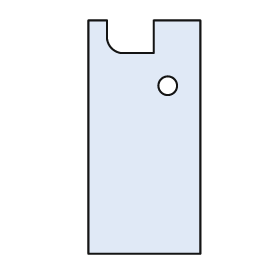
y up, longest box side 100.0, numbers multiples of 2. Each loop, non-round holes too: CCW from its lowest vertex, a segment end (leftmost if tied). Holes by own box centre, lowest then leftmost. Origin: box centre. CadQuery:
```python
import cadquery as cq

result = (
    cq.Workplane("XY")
    .moveTo(-24.0, -50.0)
    .lineTo(24.0, -50.0)
    .lineTo(24.0, 50.0)
    .lineTo(4.0, 50.0)
    .lineTo(4.0, 36.0)
    .lineTo(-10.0, 36.0)
    .threePointArc((-14.0, 38.0), (-16.0, 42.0))
    .lineTo(-16.0, 50.0)
    .lineTo(-24.0, 50.0)
    .close()
    .moveTo(10.0, 22.0)
    .circle(4.0)
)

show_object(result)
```